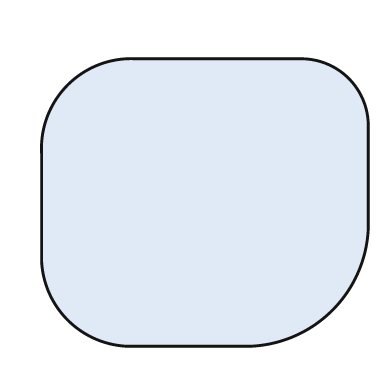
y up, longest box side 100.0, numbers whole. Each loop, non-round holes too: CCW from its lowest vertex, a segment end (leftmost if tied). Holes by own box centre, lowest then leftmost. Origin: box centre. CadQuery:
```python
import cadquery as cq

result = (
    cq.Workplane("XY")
    .moveTo(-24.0, -44.0)
    .lineTo(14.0, -44.0)
    .threePointArc((39.0, -33.0), (50.0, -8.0))
    .lineTo(50.0, 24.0)
    .threePointArc((44.0, 38.0), (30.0, 44.0))
    .lineTo(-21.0, 44.0)
    .threePointArc((-42.0, 36.0), (-50.0, 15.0))
    .lineTo(-50.0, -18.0)
    .threePointArc((-42.0, -36.0), (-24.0, -44.0))
    .close()
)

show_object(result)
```